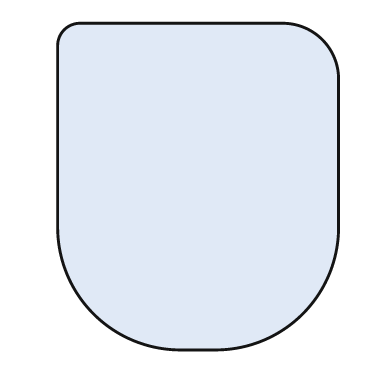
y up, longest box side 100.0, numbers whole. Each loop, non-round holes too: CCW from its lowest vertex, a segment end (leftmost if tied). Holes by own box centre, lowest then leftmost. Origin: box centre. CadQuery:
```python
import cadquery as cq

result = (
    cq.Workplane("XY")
    .moveTo(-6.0, -50.0)
    .lineTo(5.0, -50.0)
    .threePointArc((32.0, -39.0), (43.0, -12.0))
    .lineTo(43.0, 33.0)
    .threePointArc((38.0, 45.0), (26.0, 50.0))
    .lineTo(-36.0, 50.0)
    .threePointArc((-41.0, 48.0), (-43.0, 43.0))
    .lineTo(-43.0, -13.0)
    .threePointArc((-32.0, -39.0), (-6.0, -50.0))
    .close()
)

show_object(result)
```